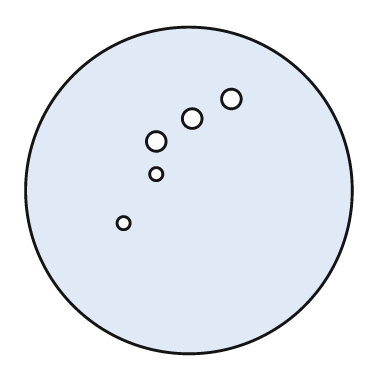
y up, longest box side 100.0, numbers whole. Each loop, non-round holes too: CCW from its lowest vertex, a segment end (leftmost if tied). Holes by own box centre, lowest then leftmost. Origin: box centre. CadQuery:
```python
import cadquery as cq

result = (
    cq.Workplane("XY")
    .moveTo(0.0, 0.0)
    .circle(50.0)
    .moveTo(-20.0, -10.0)
    .circle(2.0)
    .moveTo(-10.0, 5.0)
    .circle(2.0)
    .moveTo(-10.0, 15.0)
    .circle(3.0)
    .moveTo(1.0, 22.0)
    .circle(3.0)
    .moveTo(13.0, 28.0)
    .circle(3.0)
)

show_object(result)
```